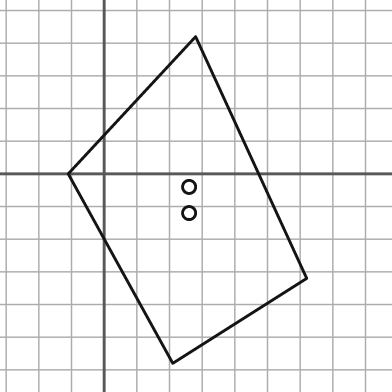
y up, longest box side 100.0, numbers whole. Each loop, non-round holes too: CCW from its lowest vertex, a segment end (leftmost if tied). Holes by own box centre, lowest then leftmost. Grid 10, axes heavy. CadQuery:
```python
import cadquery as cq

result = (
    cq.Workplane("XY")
    .moveTo(21.0, -58.0)
    .lineTo(62.0, -32.0)
    .lineTo(28.0, 42.0)
    .lineTo(-11.0, 0.0)
    .close()
    .moveTo(26.0, -12.0)
    .circle(2.0)
    .moveTo(26.0, -4.0)
    .circle(2.0)
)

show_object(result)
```